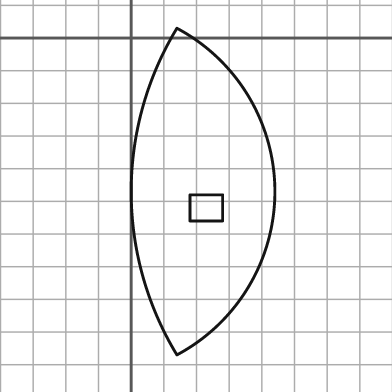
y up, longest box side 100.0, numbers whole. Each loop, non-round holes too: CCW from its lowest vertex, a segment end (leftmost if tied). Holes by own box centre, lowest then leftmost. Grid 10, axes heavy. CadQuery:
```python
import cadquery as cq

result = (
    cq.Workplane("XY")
    .moveTo(14.0, -97.0)
    .threePointArc((44.0, -47.0), (14.0, 3.0))
    .threePointArc((0.0, -47.0), (14.0, -97.0))
    .close()
    .moveTo(18.0, -56.0)
    .lineTo(28.0, -56.0)
    .lineTo(28.0, -48.0)
    .lineTo(18.0, -48.0)
    .close()
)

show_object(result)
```